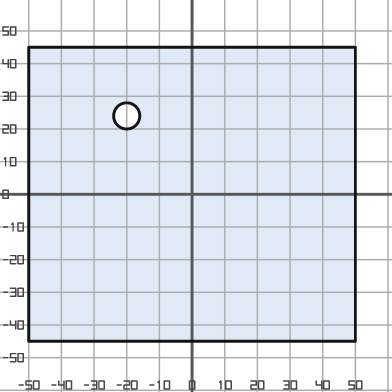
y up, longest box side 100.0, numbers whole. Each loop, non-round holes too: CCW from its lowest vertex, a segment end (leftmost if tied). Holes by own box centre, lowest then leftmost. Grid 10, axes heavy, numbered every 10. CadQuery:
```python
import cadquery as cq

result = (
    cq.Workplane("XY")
    .moveTo(-50.0, -45.0)
    .lineTo(50.0, -45.0)
    .lineTo(50.0, 45.0)
    .lineTo(-50.0, 45.0)
    .close()
    .moveTo(-20.0, 24.0)
    .circle(4.0)
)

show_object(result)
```